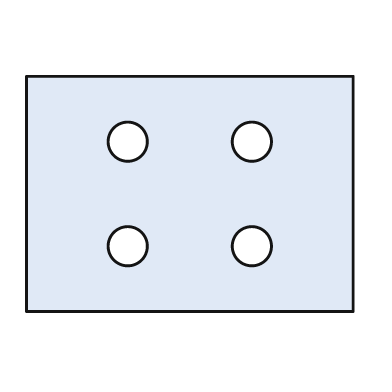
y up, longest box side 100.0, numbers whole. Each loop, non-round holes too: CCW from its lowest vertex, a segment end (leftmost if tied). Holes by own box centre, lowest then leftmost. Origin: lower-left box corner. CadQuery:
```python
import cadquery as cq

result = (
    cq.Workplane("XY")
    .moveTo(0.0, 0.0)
    .lineTo(100.0, 0.0)
    .lineTo(100.0, 72.0)
    .lineTo(0.0, 72.0)
    .close()
    .moveTo(31.0, 20.0)
    .circle(6.0)
    .moveTo(69.0, 20.0)
    .circle(6.0)
    .moveTo(31.0, 52.0)
    .circle(6.0)
    .moveTo(69.0, 52.0)
    .circle(6.0)
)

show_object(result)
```